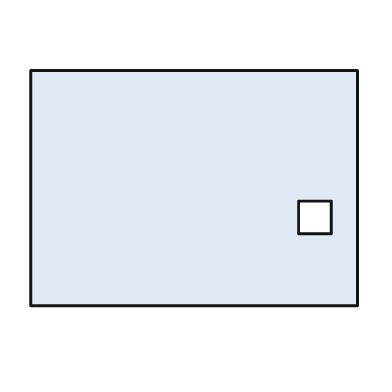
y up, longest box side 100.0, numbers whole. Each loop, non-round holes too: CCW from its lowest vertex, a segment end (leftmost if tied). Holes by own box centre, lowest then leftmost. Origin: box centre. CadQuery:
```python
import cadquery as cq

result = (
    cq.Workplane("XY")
    .moveTo(-50.0, -36.0)
    .lineTo(50.0, -36.0)
    .lineTo(50.0, 36.0)
    .lineTo(-50.0, 36.0)
    .close()
    .moveTo(32.0, -14.0)
    .lineTo(42.0, -14.0)
    .lineTo(42.0, -4.0)
    .lineTo(32.0, -4.0)
    .close()
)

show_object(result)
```